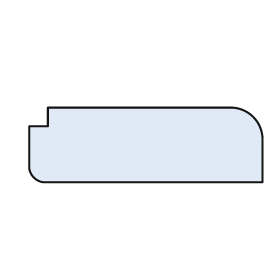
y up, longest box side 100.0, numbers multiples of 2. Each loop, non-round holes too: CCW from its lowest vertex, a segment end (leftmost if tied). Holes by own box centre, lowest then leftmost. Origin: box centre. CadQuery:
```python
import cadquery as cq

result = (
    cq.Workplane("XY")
    .moveTo(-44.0, -16.0)
    .lineTo(50.0, -16.0)
    .lineTo(50.0, 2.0)
    .threePointArc((46.0, 12.0), (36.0, 16.0))
    .lineTo(-42.0, 16.0)
    .lineTo(-42.0, 8.0)
    .lineTo(-50.0, 8.0)
    .lineTo(-50.0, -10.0)
    .threePointArc((-48.0, -14.0), (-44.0, -16.0))
    .close()
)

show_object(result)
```